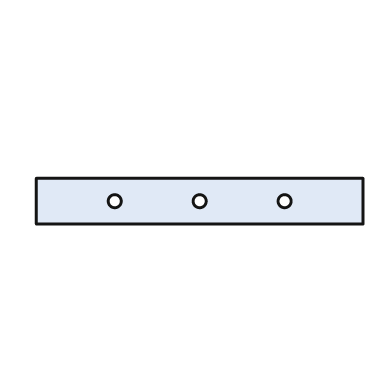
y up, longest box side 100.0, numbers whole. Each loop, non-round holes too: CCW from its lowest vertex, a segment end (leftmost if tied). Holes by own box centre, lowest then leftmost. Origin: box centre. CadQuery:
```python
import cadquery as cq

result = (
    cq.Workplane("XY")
    .moveTo(-50.0, -7.0)
    .lineTo(50.0, -7.0)
    .lineTo(50.0, 7.0)
    .lineTo(-50.0, 7.0)
    .close()
    .moveTo(-26.0, 0.0)
    .circle(2.0)
    .moveTo(0.0, 0.0)
    .circle(2.0)
    .moveTo(26.0, 0.0)
    .circle(2.0)
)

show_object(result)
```